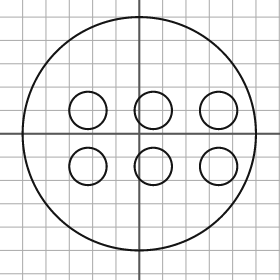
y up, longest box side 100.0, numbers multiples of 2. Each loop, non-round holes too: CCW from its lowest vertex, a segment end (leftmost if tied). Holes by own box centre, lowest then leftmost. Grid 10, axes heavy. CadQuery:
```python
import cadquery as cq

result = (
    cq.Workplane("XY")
    .moveTo(0.0, 0.0)
    .circle(50.0)
    .moveTo(-22.0, -14.0)
    .circle(8.0)
    .moveTo(6.0, -14.0)
    .circle(8.0)
    .moveTo(34.0, -14.0)
    .circle(8.0)
    .moveTo(-22.0, 10.0)
    .circle(8.0)
    .moveTo(6.0, 10.0)
    .circle(8.0)
    .moveTo(34.0, 10.0)
    .circle(8.0)
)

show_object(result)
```